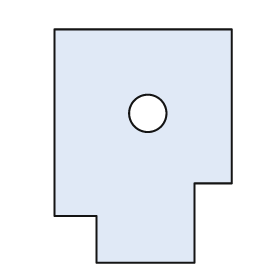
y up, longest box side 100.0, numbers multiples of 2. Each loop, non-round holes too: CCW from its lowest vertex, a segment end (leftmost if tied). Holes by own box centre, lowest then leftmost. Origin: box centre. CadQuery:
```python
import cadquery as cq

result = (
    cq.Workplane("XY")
    .moveTo(-20.0, -50.0)
    .lineTo(22.0, -50.0)
    .lineTo(22.0, -16.0)
    .lineTo(38.0, -16.0)
    .lineTo(38.0, 50.0)
    .lineTo(-38.0, 50.0)
    .lineTo(-38.0, -30.0)
    .lineTo(-20.0, -30.0)
    .close()
    .moveTo(2.0, 14.0)
    .circle(8.0)
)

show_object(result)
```